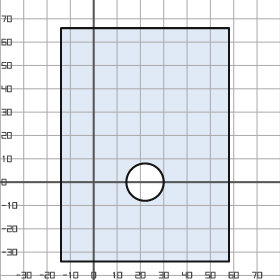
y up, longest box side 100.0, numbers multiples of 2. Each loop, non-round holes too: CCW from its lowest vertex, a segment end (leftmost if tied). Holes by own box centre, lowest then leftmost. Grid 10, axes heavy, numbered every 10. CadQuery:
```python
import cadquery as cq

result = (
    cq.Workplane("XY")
    .moveTo(-14.0, -34.0)
    .lineTo(58.0, -34.0)
    .lineTo(58.0, 66.0)
    .lineTo(-14.0, 66.0)
    .close()
    .moveTo(22.0, 0.0)
    .circle(8.0)
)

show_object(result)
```